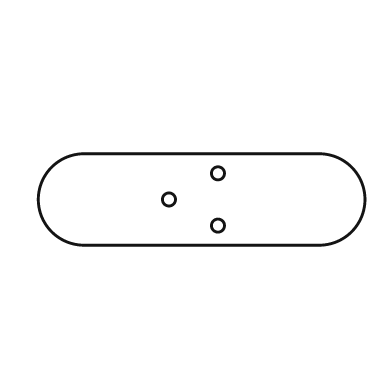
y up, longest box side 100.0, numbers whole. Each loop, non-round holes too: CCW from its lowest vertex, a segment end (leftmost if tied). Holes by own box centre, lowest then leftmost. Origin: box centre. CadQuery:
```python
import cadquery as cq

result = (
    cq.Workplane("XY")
    .moveTo(-36.0, -14.0)
    .lineTo(36.0, -14.0)
    .threePointArc((50.0, 0.0), (36.0, 14.0))
    .lineTo(-36.0, 14.0)
    .threePointArc((-50.0, 0.0), (-36.0, -14.0))
    .close()
    .moveTo(5.0, -8.0)
    .circle(2.0)
    .moveTo(-10.0, 0.0)
    .circle(2.0)
    .moveTo(5.0, 8.0)
    .circle(2.0)
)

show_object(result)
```